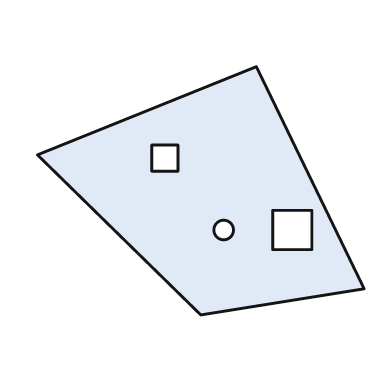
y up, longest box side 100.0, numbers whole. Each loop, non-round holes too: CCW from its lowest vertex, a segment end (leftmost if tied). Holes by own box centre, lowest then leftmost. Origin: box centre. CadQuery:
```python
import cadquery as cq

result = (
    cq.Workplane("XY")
    .moveTo(0.0, -38.0)
    .lineTo(50.0, -30.0)
    .lineTo(17.0, 38.0)
    .lineTo(-50.0, 11.0)
    .close()
    .moveTo(7.0, -12.0)
    .circle(3.0)
    .moveTo(22.0, -18.0)
    .lineTo(34.0, -18.0)
    .lineTo(34.0, -6.0)
    .lineTo(22.0, -6.0)
    .close()
    .moveTo(-15.0, 6.0)
    .lineTo(-7.0, 6.0)
    .lineTo(-7.0, 14.0)
    .lineTo(-15.0, 14.0)
    .close()
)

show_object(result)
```